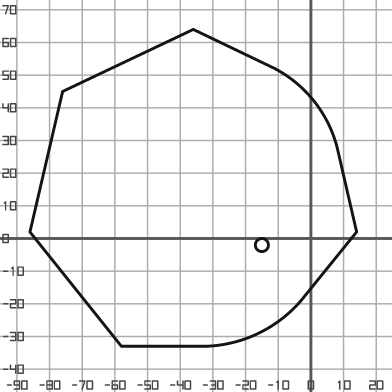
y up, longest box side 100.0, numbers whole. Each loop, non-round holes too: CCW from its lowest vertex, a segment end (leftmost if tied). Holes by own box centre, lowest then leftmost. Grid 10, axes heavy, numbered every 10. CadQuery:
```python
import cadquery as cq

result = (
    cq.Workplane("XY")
    .moveTo(-58.0, -33.0)
    .lineTo(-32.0, -33.0)
    .threePointArc((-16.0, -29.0), (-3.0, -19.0))
    .lineTo(14.0, 2.0)
    .lineTo(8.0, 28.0)
    .threePointArc((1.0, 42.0), (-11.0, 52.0))
    .lineTo(-36.0, 64.0)
    .lineTo(-76.0, 45.0)
    .lineTo(-86.0, 2.0)
    .close()
    .moveTo(-15.0, -2.0)
    .circle(2.0)
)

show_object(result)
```